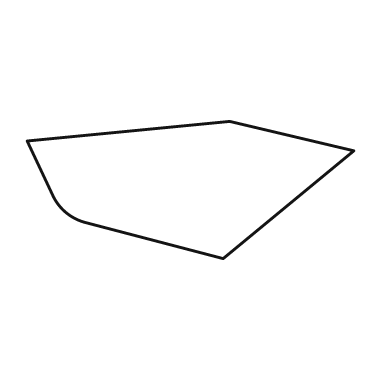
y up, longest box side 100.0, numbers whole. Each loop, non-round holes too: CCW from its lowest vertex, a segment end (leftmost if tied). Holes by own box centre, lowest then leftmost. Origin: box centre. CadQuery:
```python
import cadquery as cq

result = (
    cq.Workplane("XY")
    .moveTo(10.0, -21.0)
    .lineTo(50.0, 12.0)
    .lineTo(12.0, 21.0)
    .lineTo(-50.0, 15.0)
    .lineTo(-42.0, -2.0)
    .threePointArc((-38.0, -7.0), (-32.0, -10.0))
    .close()
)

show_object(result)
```